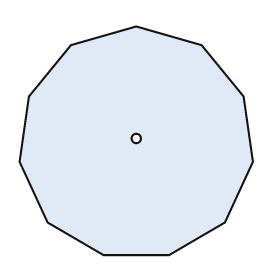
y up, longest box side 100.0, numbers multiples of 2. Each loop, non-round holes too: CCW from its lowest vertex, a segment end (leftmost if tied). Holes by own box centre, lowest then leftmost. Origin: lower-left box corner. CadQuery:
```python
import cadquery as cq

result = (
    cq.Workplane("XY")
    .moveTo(36.0, 0.0)
    .lineTo(64.0, 0.0)
    .lineTo(88.0, 14.0)
    .lineTo(100.0, 40.0)
    .lineTo(96.0, 68.0)
    .lineTo(78.0, 90.0)
    .lineTo(50.0, 98.0)
    .lineTo(22.0, 90.0)
    .lineTo(4.0, 68.0)
    .lineTo(0.0, 40.0)
    .lineTo(12.0, 14.0)
    .close()
    .moveTo(50.0, 50.0)
    .circle(2.0)
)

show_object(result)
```